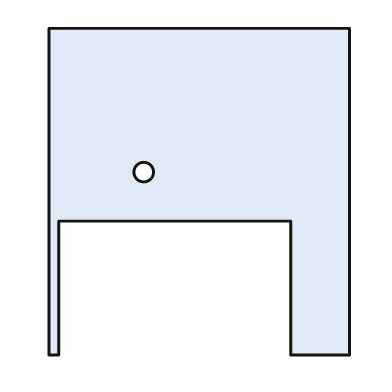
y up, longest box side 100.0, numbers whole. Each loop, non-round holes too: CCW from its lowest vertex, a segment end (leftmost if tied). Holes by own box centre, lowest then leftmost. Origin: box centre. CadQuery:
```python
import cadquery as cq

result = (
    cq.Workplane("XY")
    .moveTo(-46.0, -50.0)
    .lineTo(-43.0, -50.0)
    .lineTo(-43.0, -9.0)
    .lineTo(28.0, -9.0)
    .lineTo(28.0, -50.0)
    .lineTo(46.0, -50.0)
    .lineTo(46.0, 50.0)
    .lineTo(-46.0, 50.0)
    .close()
    .moveTo(-17.0, 6.0)
    .circle(3.0)
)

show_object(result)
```